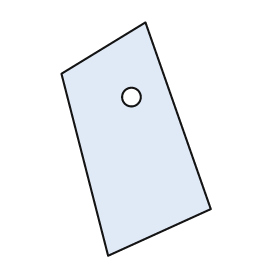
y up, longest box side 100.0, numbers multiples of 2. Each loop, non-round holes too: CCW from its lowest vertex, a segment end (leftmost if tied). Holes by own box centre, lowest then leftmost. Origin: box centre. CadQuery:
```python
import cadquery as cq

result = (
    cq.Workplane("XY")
    .moveTo(-12.0, -50.0)
    .lineTo(32.0, -30.0)
    .lineTo(4.0, 50.0)
    .lineTo(-32.0, 28.0)
    .close()
    .moveTo(-2.0, 18.0)
    .circle(4.0)
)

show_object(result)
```